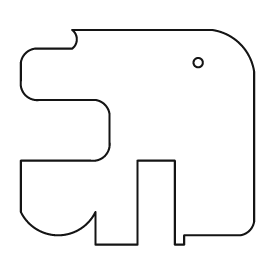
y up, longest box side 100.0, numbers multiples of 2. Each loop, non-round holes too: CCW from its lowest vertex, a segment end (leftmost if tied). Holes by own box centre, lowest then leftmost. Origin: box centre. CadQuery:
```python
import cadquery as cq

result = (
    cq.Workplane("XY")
    .moveTo(-18.0, -46.0)
    .lineTo(0.0, -46.0)
    .lineTo(0.0, -10.0)
    .lineTo(16.0, -10.0)
    .lineTo(16.0, -46.0)
    .lineTo(20.0, -46.0)
    .lineTo(20.0, -42.0)
    .lineTo(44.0, -42.0)
    .threePointArc((48.0, -40.0), (50.0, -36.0))
    .lineTo(50.0, 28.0)
    .threePointArc((44.0, 40.0), (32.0, 46.0))
    .lineTo(-28.0, 46.0)
    .threePointArc((-26.0, 42.0), (-28.0, 38.0))
    .lineTo(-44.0, 38.0)
    .threePointArc((-48.0, 36.0), (-50.0, 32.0))
    .lineTo(-50.0, 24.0)
    .threePointArc((-48.0, 18.0), (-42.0, 16.0))
    .lineTo(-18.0, 16.0)
    .threePointArc((-14.0, 14.0), (-12.0, 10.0))
    .lineTo(-12.0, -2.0)
    .threePointArc((-14.0, -8.0), (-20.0, -10.0))
    .lineTo(-50.0, -10.0)
    .lineTo(-50.0, -32.0)
    .threePointArc((-34.0, -42.0), (-18.0, -32.0))
    .close()
    .moveTo(26.0, 32.0)
    .circle(2.0)
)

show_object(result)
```